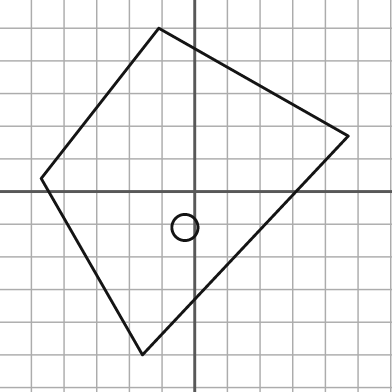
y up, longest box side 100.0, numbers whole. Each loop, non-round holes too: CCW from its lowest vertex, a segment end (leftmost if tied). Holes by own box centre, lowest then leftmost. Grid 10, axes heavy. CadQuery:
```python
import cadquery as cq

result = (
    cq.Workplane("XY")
    .moveTo(-16.0, -50.0)
    .lineTo(47.0, 17.0)
    .lineTo(-11.0, 50.0)
    .lineTo(-47.0, 4.0)
    .close()
    .moveTo(-3.0, -11.0)
    .circle(4.0)
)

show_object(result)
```